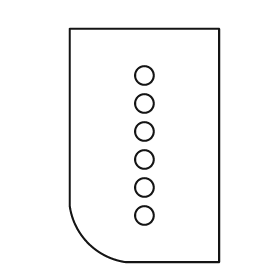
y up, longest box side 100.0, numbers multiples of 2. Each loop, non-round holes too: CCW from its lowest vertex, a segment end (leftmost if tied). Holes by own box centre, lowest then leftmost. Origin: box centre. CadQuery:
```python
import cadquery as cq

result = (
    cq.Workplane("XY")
    .moveTo(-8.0, -50.0)
    .lineTo(32.0, -50.0)
    .lineTo(32.0, 50.0)
    .lineTo(-32.0, 50.0)
    .lineTo(-32.0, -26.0)
    .threePointArc((-24.0, -42.0), (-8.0, -50.0))
    .close()
    .moveTo(0.0, -30.0)
    .circle(4.0)
    .moveTo(0.0, -18.0)
    .circle(4.0)
    .moveTo(0.0, -6.0)
    .circle(4.0)
    .moveTo(0.0, 6.0)
    .circle(4.0)
    .moveTo(0.0, 18.0)
    .circle(4.0)
    .moveTo(0.0, 30.0)
    .circle(4.0)
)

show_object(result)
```